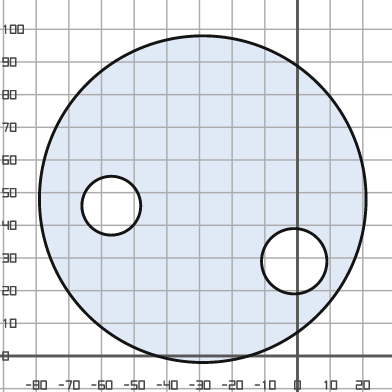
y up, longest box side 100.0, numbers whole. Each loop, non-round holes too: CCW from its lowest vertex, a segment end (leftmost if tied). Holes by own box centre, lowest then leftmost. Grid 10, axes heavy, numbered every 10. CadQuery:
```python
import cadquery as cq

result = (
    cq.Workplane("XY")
    .moveTo(-29.0, 48.0)
    .circle(50.0)
    .moveTo(-1.0, 29.0)
    .circle(10.0)
    .moveTo(-57.0, 46.0)
    .circle(9.0)
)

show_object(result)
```